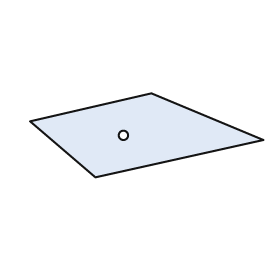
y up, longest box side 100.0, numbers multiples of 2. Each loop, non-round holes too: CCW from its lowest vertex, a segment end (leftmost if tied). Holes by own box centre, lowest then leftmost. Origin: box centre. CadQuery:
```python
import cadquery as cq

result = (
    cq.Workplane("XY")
    .moveTo(-22.0, -18.0)
    .lineTo(50.0, -2.0)
    .lineTo(2.0, 18.0)
    .lineTo(-50.0, 6.0)
    .close()
    .moveTo(-10.0, 0.0)
    .circle(2.0)
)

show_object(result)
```